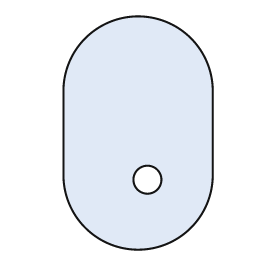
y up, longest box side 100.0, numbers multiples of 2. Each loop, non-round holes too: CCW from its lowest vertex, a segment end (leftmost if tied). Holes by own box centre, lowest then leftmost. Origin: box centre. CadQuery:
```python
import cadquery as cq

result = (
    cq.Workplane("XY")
    .moveTo(-32.0, -18.0)
    .threePointArc((0.0, -50.0), (32.0, -18.0))
    .lineTo(32.0, 18.0)
    .threePointArc((0.0, 50.0), (-32.0, 18.0))
    .close()
    .moveTo(4.0, -20.0)
    .circle(6.0)
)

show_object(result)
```